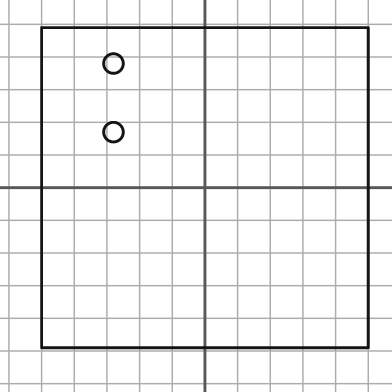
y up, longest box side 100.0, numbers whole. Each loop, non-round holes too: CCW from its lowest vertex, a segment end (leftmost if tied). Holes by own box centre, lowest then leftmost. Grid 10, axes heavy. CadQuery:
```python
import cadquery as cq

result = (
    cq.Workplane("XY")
    .moveTo(-50.0, -49.0)
    .lineTo(50.0, -49.0)
    .lineTo(50.0, 49.0)
    .lineTo(-50.0, 49.0)
    .close()
    .moveTo(-28.0, 17.0)
    .circle(3.0)
    .moveTo(-28.0, 38.0)
    .circle(3.0)
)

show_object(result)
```